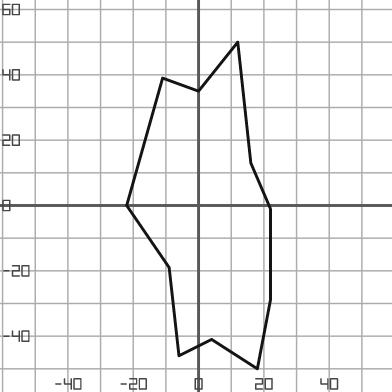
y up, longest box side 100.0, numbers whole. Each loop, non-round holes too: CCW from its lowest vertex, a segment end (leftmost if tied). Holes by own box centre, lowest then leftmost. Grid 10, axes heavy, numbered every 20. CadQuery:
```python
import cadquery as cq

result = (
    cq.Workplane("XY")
    .moveTo(18.0, -50.0)
    .lineTo(22.0, -29.0)
    .lineTo(22.0, -1.0)
    .lineTo(16.0, 13.0)
    .lineTo(12.0, 50.0)
    .lineTo(0.0, 35.0)
    .lineTo(-11.0, 39.0)
    .lineTo(-22.0, 0.0)
    .lineTo(-9.0, -19.0)
    .lineTo(-6.0, -46.0)
    .lineTo(4.0, -41.0)
    .close()
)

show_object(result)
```